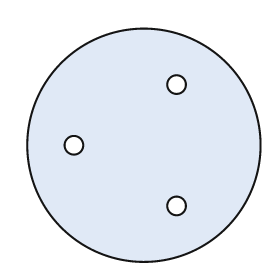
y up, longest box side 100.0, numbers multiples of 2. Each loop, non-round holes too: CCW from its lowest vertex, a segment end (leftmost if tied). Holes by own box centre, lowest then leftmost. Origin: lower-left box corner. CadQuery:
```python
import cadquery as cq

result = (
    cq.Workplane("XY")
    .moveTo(50.0, 50.0)
    .circle(50.0)
    .moveTo(64.0, 24.0)
    .circle(4.0)
    .moveTo(20.0, 50.0)
    .circle(4.0)
    .moveTo(64.0, 76.0)
    .circle(4.0)
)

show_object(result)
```